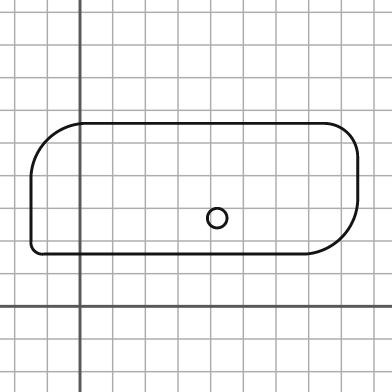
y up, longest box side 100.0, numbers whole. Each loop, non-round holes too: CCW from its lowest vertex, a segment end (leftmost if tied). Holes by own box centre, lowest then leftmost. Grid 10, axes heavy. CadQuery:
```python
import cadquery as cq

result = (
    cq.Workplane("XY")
    .moveTo(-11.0, 16.0)
    .lineTo(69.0, 16.0)
    .threePointArc((80.0, 21.0), (85.0, 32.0))
    .lineTo(85.0, 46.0)
    .threePointArc((82.0, 53.0), (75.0, 56.0))
    .lineTo(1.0, 56.0)
    .threePointArc((-10.0, 51.0), (-15.0, 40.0))
    .lineTo(-15.0, 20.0)
    .threePointArc((-14.0, 17.0), (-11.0, 16.0))
    .close()
    .moveTo(42.0, 27.0)
    .circle(3.0)
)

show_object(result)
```